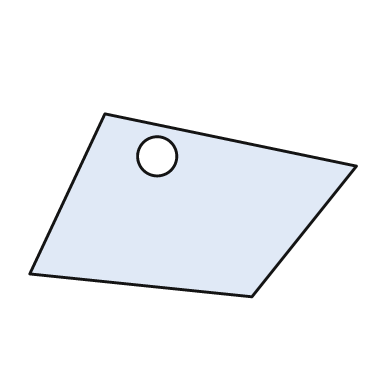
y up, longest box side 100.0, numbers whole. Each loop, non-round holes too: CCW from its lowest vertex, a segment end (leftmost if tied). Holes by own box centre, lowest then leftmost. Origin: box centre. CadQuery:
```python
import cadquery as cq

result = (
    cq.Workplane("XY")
    .moveTo(18.0, -28.0)
    .lineTo(50.0, 12.0)
    .lineTo(-27.0, 28.0)
    .lineTo(-50.0, -21.0)
    .close()
    .moveTo(-11.0, 15.0)
    .circle(6.0)
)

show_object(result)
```